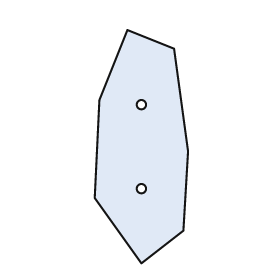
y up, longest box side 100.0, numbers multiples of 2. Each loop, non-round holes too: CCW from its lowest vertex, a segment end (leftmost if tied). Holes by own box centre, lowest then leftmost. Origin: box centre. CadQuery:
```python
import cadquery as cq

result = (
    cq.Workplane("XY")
    .moveTo(0.0, -50.0)
    .lineTo(18.0, -36.0)
    .lineTo(20.0, -2.0)
    .lineTo(14.0, 42.0)
    .lineTo(-6.0, 50.0)
    .lineTo(-18.0, 20.0)
    .lineTo(-20.0, -22.0)
    .close()
    .moveTo(0.0, -18.0)
    .circle(2.0)
    .moveTo(0.0, 18.0)
    .circle(2.0)
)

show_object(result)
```